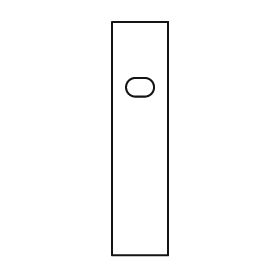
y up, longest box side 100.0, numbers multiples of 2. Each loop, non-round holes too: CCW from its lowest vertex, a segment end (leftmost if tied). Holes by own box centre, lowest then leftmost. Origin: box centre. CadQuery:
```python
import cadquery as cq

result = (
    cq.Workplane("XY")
    .moveTo(-12.0, -50.0)
    .lineTo(12.0, -50.0)
    .lineTo(12.0, 50.0)
    .lineTo(-12.0, 50.0)
    .close()
    .moveTo(-2.0, 18.0)
    .lineTo(2.0, 18.0)
    .threePointArc((6.0, 22.0), (2.0, 26.0))
    .lineTo(-2.0, 26.0)
    .threePointArc((-6.0, 22.0), (-2.0, 18.0))
    .close()
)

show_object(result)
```